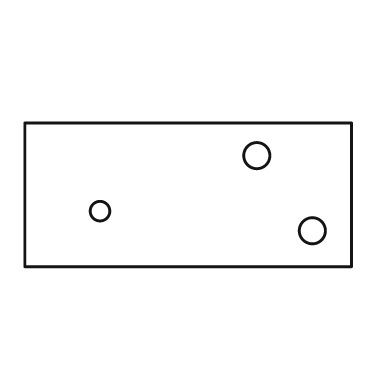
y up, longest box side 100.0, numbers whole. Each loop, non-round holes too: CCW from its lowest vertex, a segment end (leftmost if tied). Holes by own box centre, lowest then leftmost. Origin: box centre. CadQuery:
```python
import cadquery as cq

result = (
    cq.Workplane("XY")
    .moveTo(-50.0, -22.0)
    .lineTo(50.0, -22.0)
    .lineTo(50.0, 22.0)
    .lineTo(-50.0, 22.0)
    .close()
    .moveTo(38.0, -11.0)
    .circle(4.0)
    .moveTo(-27.0, -5.0)
    .circle(3.0)
    .moveTo(21.0, 12.0)
    .circle(4.0)
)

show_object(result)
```